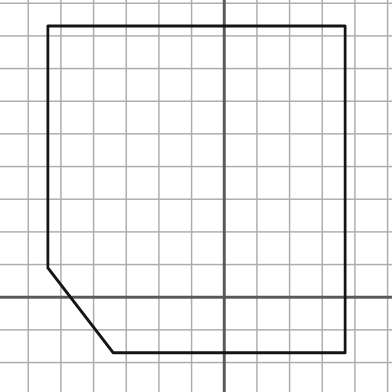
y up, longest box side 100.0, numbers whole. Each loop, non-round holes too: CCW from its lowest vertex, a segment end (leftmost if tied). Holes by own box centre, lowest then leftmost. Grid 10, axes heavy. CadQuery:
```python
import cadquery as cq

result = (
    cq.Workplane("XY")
    .moveTo(-34.0, -17.0)
    .lineTo(37.0, -17.0)
    .lineTo(37.0, 83.0)
    .lineTo(-54.0, 83.0)
    .lineTo(-54.0, 9.0)
    .close()
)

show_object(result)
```